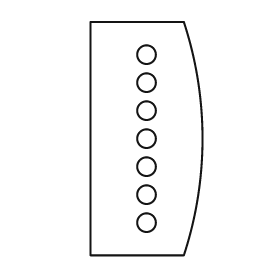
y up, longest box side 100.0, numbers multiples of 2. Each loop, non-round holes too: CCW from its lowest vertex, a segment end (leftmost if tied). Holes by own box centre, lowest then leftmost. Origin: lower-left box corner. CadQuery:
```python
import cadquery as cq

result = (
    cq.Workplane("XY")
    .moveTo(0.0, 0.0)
    .lineTo(40.0, 0.0)
    .threePointArc((48.0, 50.0), (40.0, 100.0))
    .lineTo(0.0, 100.0)
    .close()
    .moveTo(24.0, 14.0)
    .circle(4.0)
    .moveTo(24.0, 26.0)
    .circle(4.0)
    .moveTo(24.0, 38.0)
    .circle(4.0)
    .moveTo(24.0, 50.0)
    .circle(4.0)
    .moveTo(24.0, 62.0)
    .circle(4.0)
    .moveTo(24.0, 74.0)
    .circle(4.0)
    .moveTo(24.0, 86.0)
    .circle(4.0)
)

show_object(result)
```